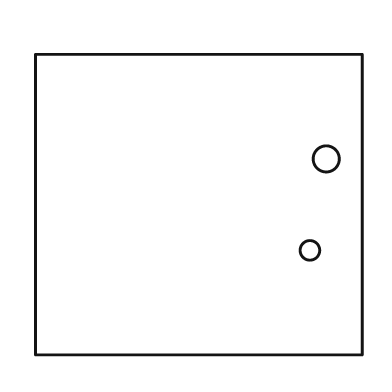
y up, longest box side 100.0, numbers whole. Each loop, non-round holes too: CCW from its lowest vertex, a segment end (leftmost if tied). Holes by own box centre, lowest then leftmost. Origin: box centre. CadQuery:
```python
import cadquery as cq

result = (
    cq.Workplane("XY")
    .moveTo(-50.0, -46.0)
    .lineTo(50.0, -46.0)
    .lineTo(50.0, 46.0)
    .lineTo(-50.0, 46.0)
    .close()
    .moveTo(34.0, -14.0)
    .circle(3.0)
    .moveTo(39.0, 14.0)
    .circle(4.0)
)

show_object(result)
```